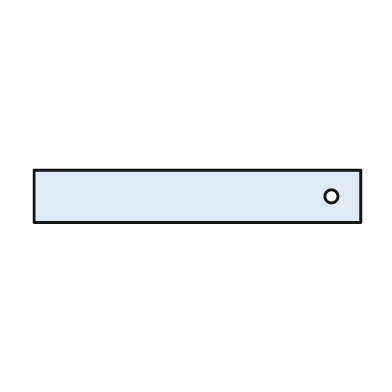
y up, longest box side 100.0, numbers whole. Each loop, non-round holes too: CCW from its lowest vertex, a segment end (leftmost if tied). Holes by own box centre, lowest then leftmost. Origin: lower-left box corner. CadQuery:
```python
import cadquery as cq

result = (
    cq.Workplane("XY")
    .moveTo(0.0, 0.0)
    .lineTo(100.0, 0.0)
    .lineTo(100.0, 16.0)
    .lineTo(0.0, 16.0)
    .close()
    .moveTo(91.0, 8.0)
    .circle(2.0)
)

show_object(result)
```